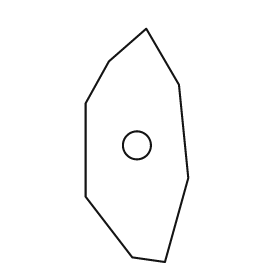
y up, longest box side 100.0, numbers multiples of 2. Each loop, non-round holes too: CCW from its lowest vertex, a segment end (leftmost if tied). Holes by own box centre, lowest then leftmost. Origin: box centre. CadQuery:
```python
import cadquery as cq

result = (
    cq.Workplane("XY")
    .moveTo(12.0, -50.0)
    .lineTo(22.0, -14.0)
    .lineTo(18.0, 26.0)
    .lineTo(4.0, 50.0)
    .lineTo(-12.0, 36.0)
    .lineTo(-22.0, 18.0)
    .lineTo(-22.0, -22.0)
    .lineTo(-2.0, -48.0)
    .close()
    .moveTo(0.0, 0.0)
    .circle(6.0)
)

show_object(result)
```